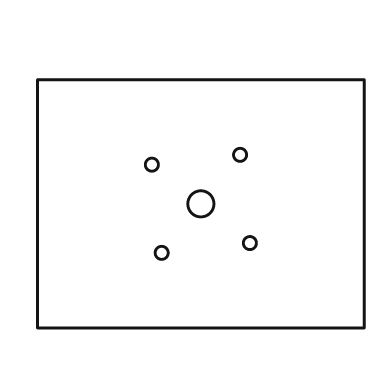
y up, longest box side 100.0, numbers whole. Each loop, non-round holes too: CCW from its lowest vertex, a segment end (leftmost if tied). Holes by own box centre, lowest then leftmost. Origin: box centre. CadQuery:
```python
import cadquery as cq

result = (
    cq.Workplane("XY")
    .moveTo(-50.0, -38.0)
    .lineTo(50.0, -38.0)
    .lineTo(50.0, 38.0)
    .lineTo(-50.0, 38.0)
    .close()
    .moveTo(-12.0, -15.0)
    .circle(2.0)
    .moveTo(15.0, -12.0)
    .circle(2.0)
    .moveTo(0.0, 0.0)
    .circle(4.0)
    .moveTo(-15.0, 12.0)
    .circle(2.0)
    .moveTo(12.0, 15.0)
    .circle(2.0)
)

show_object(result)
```